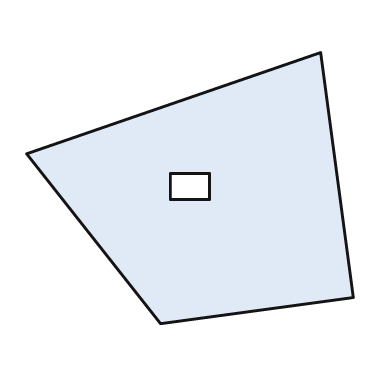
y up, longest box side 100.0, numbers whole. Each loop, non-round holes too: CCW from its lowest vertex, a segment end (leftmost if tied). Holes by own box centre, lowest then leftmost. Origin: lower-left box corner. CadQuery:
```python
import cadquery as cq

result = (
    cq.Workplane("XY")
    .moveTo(41.0, 0.0)
    .lineTo(100.0, 8.0)
    .lineTo(90.0, 83.0)
    .lineTo(0.0, 52.0)
    .close()
    .moveTo(44.0, 38.0)
    .lineTo(56.0, 38.0)
    .lineTo(56.0, 46.0)
    .lineTo(44.0, 46.0)
    .close()
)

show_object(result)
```